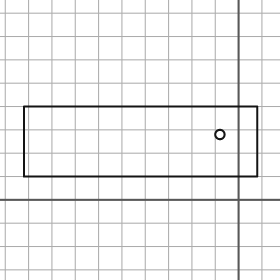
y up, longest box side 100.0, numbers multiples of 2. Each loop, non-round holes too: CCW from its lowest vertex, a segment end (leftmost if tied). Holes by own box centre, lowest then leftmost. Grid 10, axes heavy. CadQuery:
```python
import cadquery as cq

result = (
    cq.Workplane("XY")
    .moveTo(-92.0, 10.0)
    .lineTo(8.0, 10.0)
    .lineTo(8.0, 40.0)
    .lineTo(-92.0, 40.0)
    .close()
    .moveTo(-8.0, 28.0)
    .circle(2.0)
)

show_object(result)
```